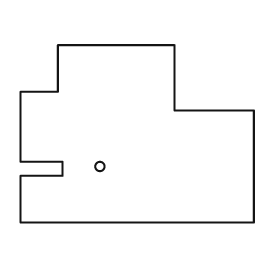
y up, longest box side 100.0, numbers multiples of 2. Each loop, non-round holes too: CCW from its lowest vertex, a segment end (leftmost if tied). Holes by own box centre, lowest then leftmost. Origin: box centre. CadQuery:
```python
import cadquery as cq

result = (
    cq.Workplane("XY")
    .moveTo(-50.0, -38.0)
    .lineTo(50.0, -38.0)
    .lineTo(50.0, 10.0)
    .lineTo(16.0, 10.0)
    .lineTo(16.0, 38.0)
    .lineTo(-34.0, 38.0)
    .lineTo(-34.0, 18.0)
    .lineTo(-50.0, 18.0)
    .lineTo(-50.0, -12.0)
    .lineTo(-32.0, -12.0)
    .lineTo(-32.0, -18.0)
    .lineTo(-50.0, -18.0)
    .close()
    .moveTo(-16.0, -14.0)
    .circle(2.0)
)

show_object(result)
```